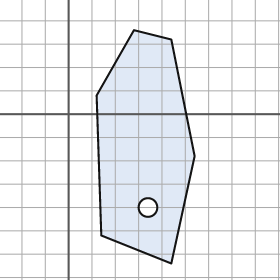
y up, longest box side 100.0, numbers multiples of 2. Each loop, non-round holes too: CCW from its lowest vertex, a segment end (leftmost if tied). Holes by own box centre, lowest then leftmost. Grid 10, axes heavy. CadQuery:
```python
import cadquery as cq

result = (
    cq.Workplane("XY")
    .moveTo(44.0, -64.0)
    .lineTo(54.0, -18.0)
    .lineTo(44.0, 32.0)
    .lineTo(28.0, 36.0)
    .lineTo(12.0, 8.0)
    .lineTo(14.0, -52.0)
    .close()
    .moveTo(34.0, -40.0)
    .circle(4.0)
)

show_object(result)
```